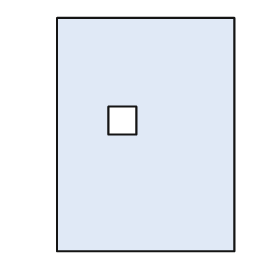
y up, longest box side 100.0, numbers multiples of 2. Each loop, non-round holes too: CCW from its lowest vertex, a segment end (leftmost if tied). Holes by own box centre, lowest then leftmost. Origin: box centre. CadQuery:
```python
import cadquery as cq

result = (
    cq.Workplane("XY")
    .moveTo(-38.0, -50.0)
    .lineTo(38.0, -50.0)
    .lineTo(38.0, 50.0)
    .lineTo(-38.0, 50.0)
    .close()
    .moveTo(-16.0, 0.0)
    .lineTo(-4.0, 0.0)
    .lineTo(-4.0, 12.0)
    .lineTo(-16.0, 12.0)
    .close()
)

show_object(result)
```